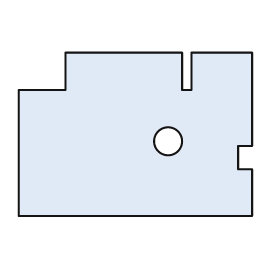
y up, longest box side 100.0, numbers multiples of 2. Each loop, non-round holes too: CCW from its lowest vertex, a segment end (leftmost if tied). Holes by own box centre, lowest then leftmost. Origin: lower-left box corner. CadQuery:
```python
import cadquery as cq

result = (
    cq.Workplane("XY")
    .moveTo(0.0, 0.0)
    .lineTo(100.0, 0.0)
    .lineTo(100.0, 20.0)
    .lineTo(94.0, 20.0)
    .lineTo(94.0, 30.0)
    .lineTo(100.0, 30.0)
    .lineTo(100.0, 70.0)
    .lineTo(74.0, 70.0)
    .lineTo(74.0, 54.0)
    .lineTo(70.0, 54.0)
    .lineTo(70.0, 70.0)
    .lineTo(20.0, 70.0)
    .lineTo(20.0, 54.0)
    .lineTo(0.0, 54.0)
    .close()
    .moveTo(64.0, 32.0)
    .circle(6.0)
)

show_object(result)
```